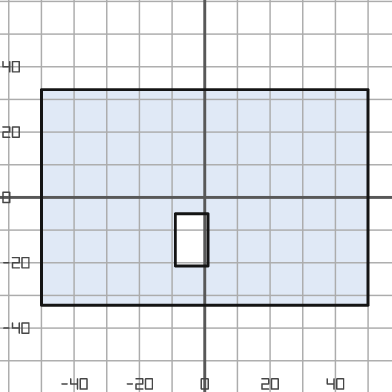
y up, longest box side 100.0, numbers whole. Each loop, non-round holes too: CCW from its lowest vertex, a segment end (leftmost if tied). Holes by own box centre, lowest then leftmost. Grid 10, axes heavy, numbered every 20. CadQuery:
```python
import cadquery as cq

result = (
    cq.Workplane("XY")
    .moveTo(-50.0, -33.0)
    .lineTo(50.0, -33.0)
    .lineTo(50.0, 33.0)
    .lineTo(-50.0, 33.0)
    .close()
    .moveTo(-9.0, -21.0)
    .lineTo(1.0, -21.0)
    .lineTo(1.0, -5.0)
    .lineTo(-9.0, -5.0)
    .close()
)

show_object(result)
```